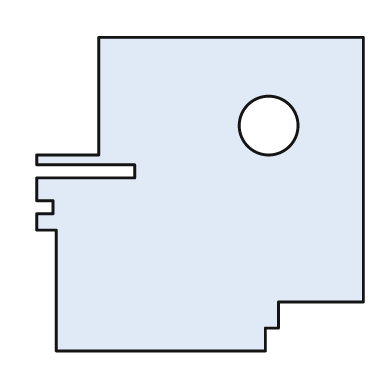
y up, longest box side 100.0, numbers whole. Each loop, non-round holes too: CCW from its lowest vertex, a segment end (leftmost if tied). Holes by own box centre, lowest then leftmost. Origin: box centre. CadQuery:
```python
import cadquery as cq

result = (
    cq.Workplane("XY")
    .moveTo(-44.0, -48.0)
    .lineTo(20.0, -48.0)
    .lineTo(20.0, -41.0)
    .lineTo(24.0, -41.0)
    .lineTo(24.0, -33.0)
    .lineTo(50.0, -33.0)
    .lineTo(50.0, 48.0)
    .lineTo(-31.0, 48.0)
    .lineTo(-31.0, 12.0)
    .lineTo(-50.0, 12.0)
    .lineTo(-50.0, 9.0)
    .lineTo(-20.0, 9.0)
    .lineTo(-20.0, 5.0)
    .lineTo(-50.0, 5.0)
    .lineTo(-50.0, -2.0)
    .lineTo(-45.0, -2.0)
    .lineTo(-45.0, -6.0)
    .lineTo(-50.0, -6.0)
    .lineTo(-50.0, -11.0)
    .lineTo(-44.0, -11.0)
    .close()
    .moveTo(21.0, 21.0)
    .circle(9.0)
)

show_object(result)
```